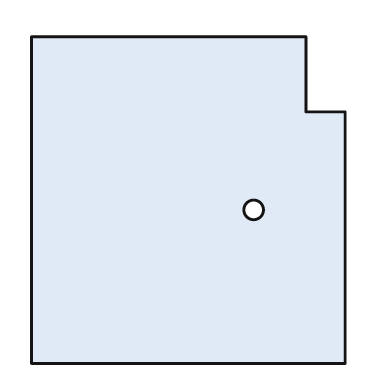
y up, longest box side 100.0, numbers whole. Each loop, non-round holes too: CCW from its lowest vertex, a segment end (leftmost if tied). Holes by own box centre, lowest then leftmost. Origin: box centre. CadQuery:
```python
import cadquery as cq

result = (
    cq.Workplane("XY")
    .moveTo(-48.0, -50.0)
    .lineTo(48.0, -50.0)
    .lineTo(48.0, 27.0)
    .lineTo(36.0, 27.0)
    .lineTo(36.0, 50.0)
    .lineTo(-48.0, 50.0)
    .close()
    .moveTo(20.0, -3.0)
    .circle(3.0)
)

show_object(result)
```